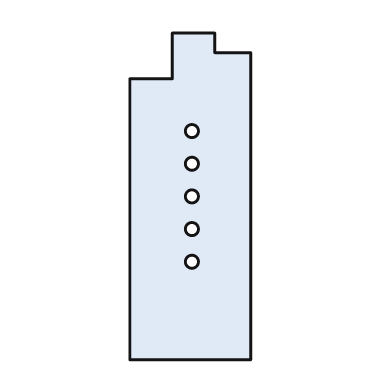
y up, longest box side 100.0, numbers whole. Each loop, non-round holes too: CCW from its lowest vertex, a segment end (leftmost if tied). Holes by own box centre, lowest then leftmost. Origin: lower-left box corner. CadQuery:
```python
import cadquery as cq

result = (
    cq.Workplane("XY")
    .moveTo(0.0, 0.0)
    .lineTo(37.0, 0.0)
    .lineTo(37.0, 94.0)
    .lineTo(26.0, 94.0)
    .lineTo(26.0, 100.0)
    .lineTo(13.0, 100.0)
    .lineTo(13.0, 86.0)
    .lineTo(0.0, 86.0)
    .close()
    .moveTo(19.0, 30.0)
    .circle(2.0)
    .moveTo(19.0, 40.0)
    .circle(2.0)
    .moveTo(19.0, 50.0)
    .circle(2.0)
    .moveTo(19.0, 60.0)
    .circle(2.0)
    .moveTo(19.0, 70.0)
    .circle(2.0)
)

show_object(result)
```